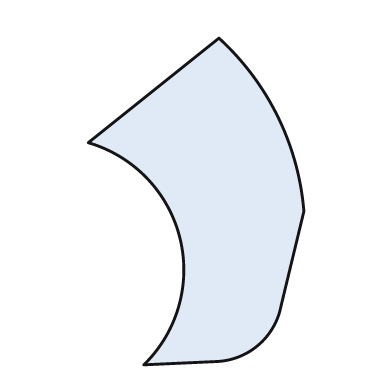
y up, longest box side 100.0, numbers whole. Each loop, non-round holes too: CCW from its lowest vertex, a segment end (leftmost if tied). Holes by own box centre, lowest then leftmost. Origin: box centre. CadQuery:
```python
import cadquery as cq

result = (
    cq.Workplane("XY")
    .moveTo(-16.0, -50.0)
    .lineTo(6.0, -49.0)
    .threePointArc((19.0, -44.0), (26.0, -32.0))
    .lineTo(33.0, -3.0)
    .threePointArc((25.0, 26.0), (7.0, 50.0))
    .lineTo(-33.0, 18.0)
    .threePointArc((-5.0, -11.0), (-16.0, -50.0))
    .close()
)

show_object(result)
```